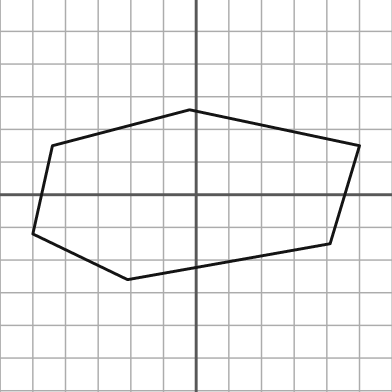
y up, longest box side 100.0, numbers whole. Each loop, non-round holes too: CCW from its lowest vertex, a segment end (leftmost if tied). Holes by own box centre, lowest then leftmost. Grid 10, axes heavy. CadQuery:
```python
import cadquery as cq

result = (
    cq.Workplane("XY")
    .moveTo(-21.0, -26.0)
    .lineTo(41.0, -15.0)
    .lineTo(50.0, 15.0)
    .lineTo(-2.0, 26.0)
    .lineTo(-44.0, 15.0)
    .lineTo(-50.0, -12.0)
    .close()
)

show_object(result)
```